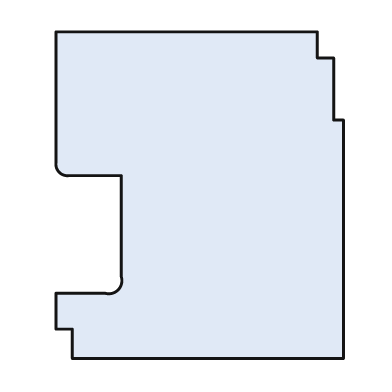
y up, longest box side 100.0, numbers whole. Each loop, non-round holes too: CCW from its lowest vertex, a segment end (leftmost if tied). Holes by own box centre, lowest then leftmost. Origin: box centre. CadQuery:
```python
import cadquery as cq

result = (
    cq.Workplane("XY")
    .moveTo(-39.0, -50.0)
    .lineTo(44.0, -50.0)
    .lineTo(44.0, 23.0)
    .lineTo(41.0, 23.0)
    .lineTo(41.0, 42.0)
    .lineTo(36.0, 42.0)
    .lineTo(36.0, 50.0)
    .lineTo(-44.0, 50.0)
    .lineTo(-44.0, 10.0)
    .threePointArc((-43.0, 7.0), (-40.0, 6.0))
    .lineTo(-24.0, 6.0)
    .lineTo(-24.0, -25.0)
    .threePointArc((-25.0, -29.0), (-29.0, -30.0))
    .lineTo(-44.0, -30.0)
    .lineTo(-44.0, -41.0)
    .lineTo(-39.0, -41.0)
    .close()
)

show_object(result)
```